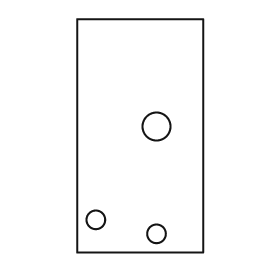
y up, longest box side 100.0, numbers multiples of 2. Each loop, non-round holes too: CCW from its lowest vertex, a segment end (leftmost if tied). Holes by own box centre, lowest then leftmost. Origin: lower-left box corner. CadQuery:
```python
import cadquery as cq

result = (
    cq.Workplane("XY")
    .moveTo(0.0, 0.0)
    .lineTo(54.0, 0.0)
    .lineTo(54.0, 100.0)
    .lineTo(0.0, 100.0)
    .close()
    .moveTo(34.0, 8.0)
    .circle(4.0)
    .moveTo(8.0, 14.0)
    .circle(4.0)
    .moveTo(34.0, 54.0)
    .circle(6.0)
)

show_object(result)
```